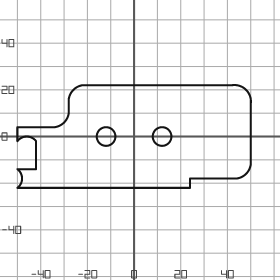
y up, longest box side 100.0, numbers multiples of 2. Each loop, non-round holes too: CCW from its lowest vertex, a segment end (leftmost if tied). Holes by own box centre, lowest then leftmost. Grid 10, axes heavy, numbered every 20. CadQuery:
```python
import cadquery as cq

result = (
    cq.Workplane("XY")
    .moveTo(-50.0, -22.0)
    .lineTo(24.0, -22.0)
    .lineTo(24.0, -18.0)
    .lineTo(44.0, -18.0)
    .threePointArc((48.0, -16.0), (50.0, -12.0))
    .lineTo(50.0, 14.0)
    .threePointArc((48.0, 20.0), (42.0, 22.0))
    .lineTo(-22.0, 22.0)
    .threePointArc((-26.0, 20.0), (-28.0, 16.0))
    .lineTo(-28.0, 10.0)
    .threePointArc((-30.0, 6.0), (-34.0, 4.0))
    .lineTo(-50.0, 4.0)
    .lineTo(-50.0, -2.0)
    .threePointArc((-46.0, 0.0), (-42.0, -2.0))
    .lineTo(-42.0, -14.0)
    .lineTo(-50.0, -14.0)
    .threePointArc((-48.0, -18.0), (-50.0, -22.0))
    .close()
    .moveTo(-12.0, 0.0)
    .circle(4.0)
    .moveTo(12.0, 0.0)
    .circle(4.0)
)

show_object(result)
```